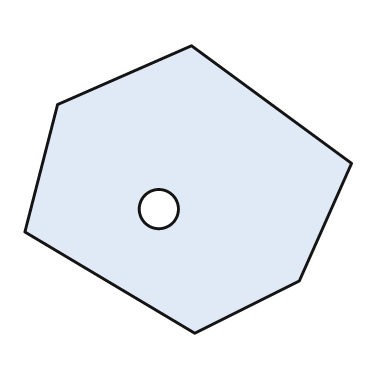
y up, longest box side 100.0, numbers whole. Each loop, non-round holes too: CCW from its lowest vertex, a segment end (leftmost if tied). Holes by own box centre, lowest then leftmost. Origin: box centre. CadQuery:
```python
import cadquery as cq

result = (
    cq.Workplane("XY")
    .moveTo(2.0, -44.0)
    .lineTo(34.0, -28.0)
    .lineTo(50.0, 8.0)
    .lineTo(1.0, 44.0)
    .lineTo(-40.0, 26.0)
    .lineTo(-50.0, -13.0)
    .close()
    .moveTo(-9.0, -6.0)
    .circle(6.0)
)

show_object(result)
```